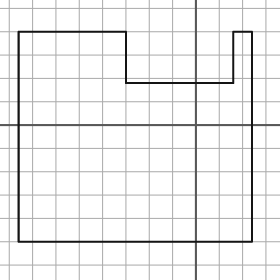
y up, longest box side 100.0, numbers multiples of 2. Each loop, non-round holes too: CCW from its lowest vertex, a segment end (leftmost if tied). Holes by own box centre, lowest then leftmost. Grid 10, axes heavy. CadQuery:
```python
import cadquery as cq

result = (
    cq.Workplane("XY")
    .moveTo(-76.0, -50.0)
    .lineTo(24.0, -50.0)
    .lineTo(24.0, 40.0)
    .lineTo(16.0, 40.0)
    .lineTo(16.0, 18.0)
    .lineTo(-30.0, 18.0)
    .lineTo(-30.0, 40.0)
    .lineTo(-76.0, 40.0)
    .close()
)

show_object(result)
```